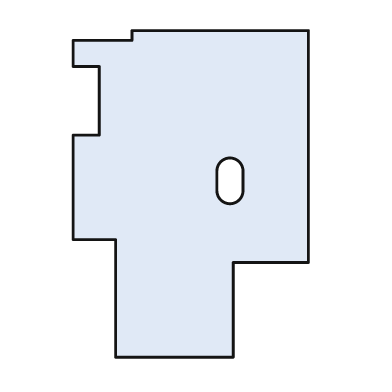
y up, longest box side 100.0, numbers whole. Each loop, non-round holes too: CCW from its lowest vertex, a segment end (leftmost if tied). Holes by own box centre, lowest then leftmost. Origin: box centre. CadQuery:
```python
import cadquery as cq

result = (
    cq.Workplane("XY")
    .moveTo(-23.0, -50.0)
    .lineTo(13.0, -50.0)
    .lineTo(13.0, -21.0)
    .lineTo(36.0, -21.0)
    .lineTo(36.0, 50.0)
    .lineTo(-18.0, 50.0)
    .lineTo(-18.0, 47.0)
    .lineTo(-36.0, 47.0)
    .lineTo(-36.0, 39.0)
    .lineTo(-28.0, 39.0)
    .lineTo(-28.0, 18.0)
    .lineTo(-36.0, 18.0)
    .lineTo(-36.0, -14.0)
    .lineTo(-23.0, -14.0)
    .close()
    .moveTo(8.0, 1.0)
    .threePointArc((12.0, -3.0), (16.0, 1.0))
    .lineTo(16.0, 7.0)
    .threePointArc((12.0, 11.0), (8.0, 7.0))
    .close()
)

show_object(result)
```